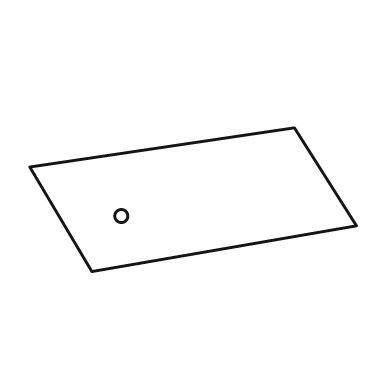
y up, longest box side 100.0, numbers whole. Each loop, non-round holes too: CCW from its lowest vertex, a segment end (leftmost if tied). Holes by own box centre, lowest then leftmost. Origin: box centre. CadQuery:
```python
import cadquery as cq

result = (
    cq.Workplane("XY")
    .moveTo(-31.0, -22.0)
    .lineTo(50.0, -8.0)
    .lineTo(31.0, 22.0)
    .lineTo(-50.0, 10.0)
    .close()
    .moveTo(-22.0, -5.0)
    .circle(2.0)
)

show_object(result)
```